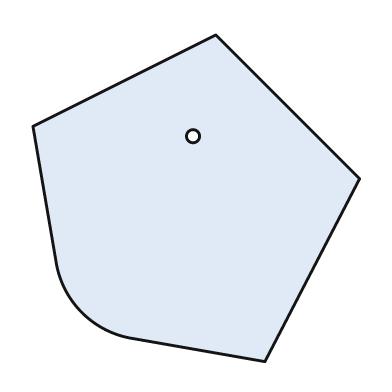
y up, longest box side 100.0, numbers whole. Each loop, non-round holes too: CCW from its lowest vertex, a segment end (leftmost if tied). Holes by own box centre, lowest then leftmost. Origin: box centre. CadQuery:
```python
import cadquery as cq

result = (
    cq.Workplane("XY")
    .moveTo(21.0, -50.0)
    .lineTo(50.0, 6.0)
    .lineTo(6.0, 50.0)
    .lineTo(-50.0, 22.0)
    .lineTo(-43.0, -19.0)
    .threePointArc((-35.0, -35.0), (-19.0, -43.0))
    .close()
    .moveTo(-1.0, 19.0)
    .circle(2.0)
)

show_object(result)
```